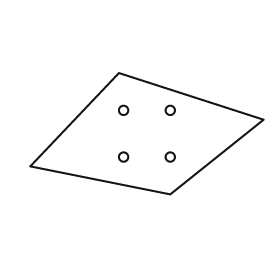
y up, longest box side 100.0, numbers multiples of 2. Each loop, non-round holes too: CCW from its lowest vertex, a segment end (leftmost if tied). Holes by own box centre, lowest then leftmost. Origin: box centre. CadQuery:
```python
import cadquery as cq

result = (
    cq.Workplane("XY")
    .moveTo(10.0, -26.0)
    .lineTo(50.0, 6.0)
    .lineTo(-12.0, 26.0)
    .lineTo(-50.0, -14.0)
    .close()
    .moveTo(-10.0, -10.0)
    .circle(2.0)
    .moveTo(10.0, -10.0)
    .circle(2.0)
    .moveTo(-10.0, 10.0)
    .circle(2.0)
    .moveTo(10.0, 10.0)
    .circle(2.0)
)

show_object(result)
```